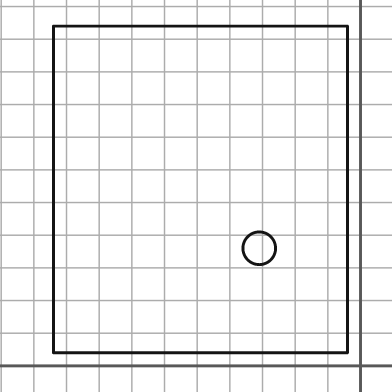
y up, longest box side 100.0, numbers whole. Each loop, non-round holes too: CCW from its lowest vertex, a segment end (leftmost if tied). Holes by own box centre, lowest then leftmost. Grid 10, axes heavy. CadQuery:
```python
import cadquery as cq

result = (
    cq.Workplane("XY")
    .moveTo(-94.0, 4.0)
    .lineTo(-4.0, 4.0)
    .lineTo(-4.0, 104.0)
    .lineTo(-94.0, 104.0)
    .close()
    .moveTo(-31.0, 36.0)
    .circle(5.0)
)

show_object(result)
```